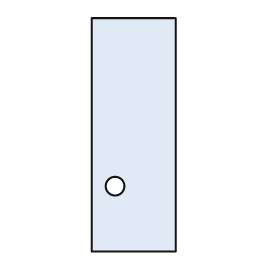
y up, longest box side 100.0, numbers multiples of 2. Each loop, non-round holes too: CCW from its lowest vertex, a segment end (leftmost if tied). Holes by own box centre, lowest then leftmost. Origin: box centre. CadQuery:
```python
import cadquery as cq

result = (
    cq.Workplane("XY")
    .moveTo(-18.0, -50.0)
    .lineTo(18.0, -50.0)
    .lineTo(18.0, 50.0)
    .lineTo(-18.0, 50.0)
    .close()
    .moveTo(-8.0, -22.0)
    .circle(4.0)
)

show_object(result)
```